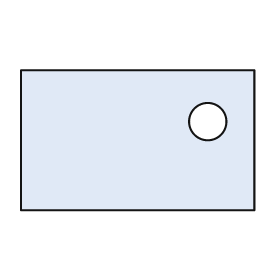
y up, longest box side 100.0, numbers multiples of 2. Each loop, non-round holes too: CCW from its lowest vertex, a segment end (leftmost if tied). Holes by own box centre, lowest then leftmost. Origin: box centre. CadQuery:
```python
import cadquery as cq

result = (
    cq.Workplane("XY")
    .moveTo(-50.0, -30.0)
    .lineTo(50.0, -30.0)
    .lineTo(50.0, 30.0)
    .lineTo(-50.0, 30.0)
    .close()
    .moveTo(30.0, 8.0)
    .circle(8.0)
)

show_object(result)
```